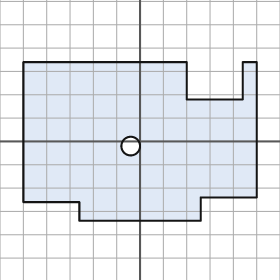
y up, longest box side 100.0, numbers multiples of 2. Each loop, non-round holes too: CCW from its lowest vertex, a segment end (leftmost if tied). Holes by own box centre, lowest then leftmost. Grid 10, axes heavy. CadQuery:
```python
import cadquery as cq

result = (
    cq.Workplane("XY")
    .moveTo(-26.0, -34.0)
    .lineTo(26.0, -34.0)
    .lineTo(26.0, -24.0)
    .lineTo(50.0, -24.0)
    .lineTo(50.0, 34.0)
    .lineTo(44.0, 34.0)
    .lineTo(44.0, 18.0)
    .lineTo(20.0, 18.0)
    .lineTo(20.0, 34.0)
    .lineTo(-50.0, 34.0)
    .lineTo(-50.0, -26.0)
    .lineTo(-26.0, -26.0)
    .close()
    .moveTo(-4.0, -2.0)
    .circle(4.0)
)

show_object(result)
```